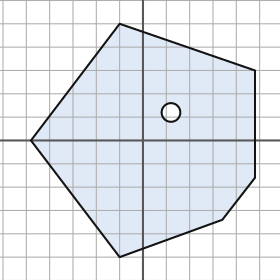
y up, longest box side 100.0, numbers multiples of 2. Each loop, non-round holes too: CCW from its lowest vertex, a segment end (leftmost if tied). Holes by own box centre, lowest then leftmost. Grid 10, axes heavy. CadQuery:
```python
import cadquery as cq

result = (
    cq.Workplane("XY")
    .moveTo(-10.0, -50.0)
    .lineTo(34.0, -34.0)
    .lineTo(48.0, -16.0)
    .lineTo(48.0, 30.0)
    .lineTo(-10.0, 50.0)
    .lineTo(-48.0, 0.0)
    .close()
    .moveTo(12.0, 12.0)
    .circle(4.0)
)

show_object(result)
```